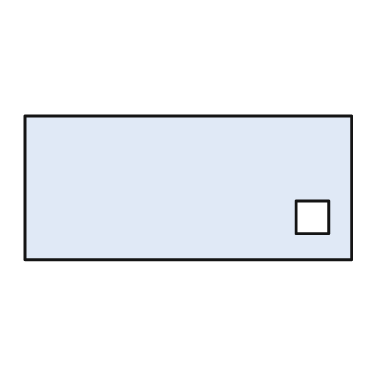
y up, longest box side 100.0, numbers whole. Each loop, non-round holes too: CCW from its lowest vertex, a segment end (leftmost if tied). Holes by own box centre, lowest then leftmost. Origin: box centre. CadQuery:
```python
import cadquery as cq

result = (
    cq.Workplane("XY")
    .moveTo(-50.0, -22.0)
    .lineTo(50.0, -22.0)
    .lineTo(50.0, 22.0)
    .lineTo(-50.0, 22.0)
    .close()
    .moveTo(33.0, -14.0)
    .lineTo(43.0, -14.0)
    .lineTo(43.0, -4.0)
    .lineTo(33.0, -4.0)
    .close()
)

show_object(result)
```